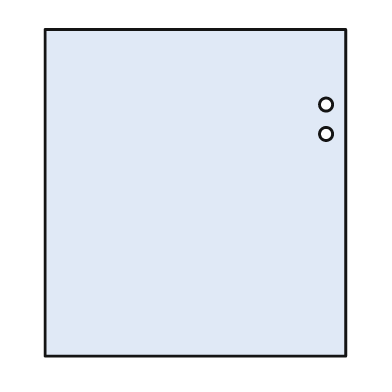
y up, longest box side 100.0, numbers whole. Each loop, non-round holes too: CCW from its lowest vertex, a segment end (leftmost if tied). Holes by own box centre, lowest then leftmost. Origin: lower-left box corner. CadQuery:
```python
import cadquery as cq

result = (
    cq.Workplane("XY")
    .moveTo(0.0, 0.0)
    .lineTo(92.0, 0.0)
    .lineTo(92.0, 100.0)
    .lineTo(0.0, 100.0)
    .close()
    .moveTo(86.0, 68.0)
    .circle(2.0)
    .moveTo(86.0, 77.0)
    .circle(2.0)
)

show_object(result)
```